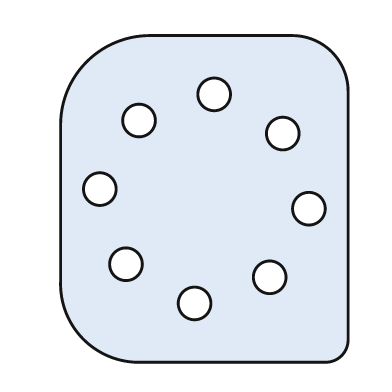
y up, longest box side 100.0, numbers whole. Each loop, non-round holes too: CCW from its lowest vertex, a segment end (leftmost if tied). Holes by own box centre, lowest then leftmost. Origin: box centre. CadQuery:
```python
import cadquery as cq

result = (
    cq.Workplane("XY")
    .moveTo(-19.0, -50.0)
    .lineTo(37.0, -50.0)
    .threePointArc((42.0, -48.0), (44.0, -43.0))
    .lineTo(44.0, 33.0)
    .threePointArc((39.0, 45.0), (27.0, 50.0))
    .lineTo(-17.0, 50.0)
    .threePointArc((-36.0, 42.0), (-44.0, 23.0))
    .lineTo(-44.0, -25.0)
    .threePointArc((-37.0, -43.0), (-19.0, -50.0))
    .close()
    .moveTo(-3.0, -32.0)
    .circle(5.0)
    .moveTo(20.0, -24.0)
    .circle(5.0)
    .moveTo(-24.0, -20.0)
    .circle(5.0)
    .moveTo(32.0, -3.0)
    .circle(5.0)
    .moveTo(-32.0, 3.0)
    .circle(5.0)
    .moveTo(24.0, 20.0)
    .circle(5.0)
    .moveTo(-20.0, 24.0)
    .circle(5.0)
    .moveTo(3.0, 32.0)
    .circle(5.0)
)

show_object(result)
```